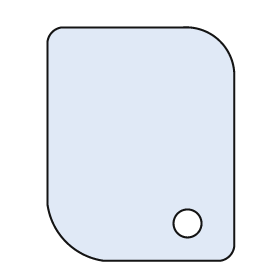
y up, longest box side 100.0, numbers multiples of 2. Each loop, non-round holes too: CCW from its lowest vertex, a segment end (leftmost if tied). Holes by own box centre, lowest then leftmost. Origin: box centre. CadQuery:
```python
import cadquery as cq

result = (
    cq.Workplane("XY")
    .moveTo(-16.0, -50.0)
    .lineTo(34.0, -50.0)
    .threePointArc((38.0, -48.0), (40.0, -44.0))
    .lineTo(40.0, 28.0)
    .threePointArc((34.0, 44.0), (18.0, 50.0))
    .lineTo(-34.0, 50.0)
    .threePointArc((-38.0, 48.0), (-40.0, 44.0))
    .lineTo(-40.0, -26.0)
    .threePointArc((-32.0, -42.0), (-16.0, -50.0))
    .close()
    .moveTo(20.0, -34.0)
    .circle(6.0)
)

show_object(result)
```